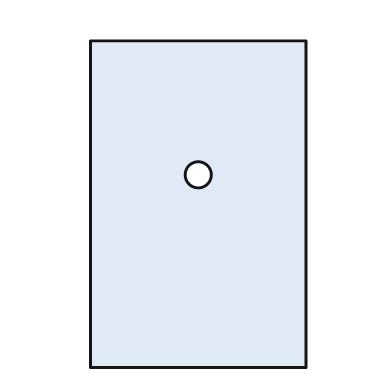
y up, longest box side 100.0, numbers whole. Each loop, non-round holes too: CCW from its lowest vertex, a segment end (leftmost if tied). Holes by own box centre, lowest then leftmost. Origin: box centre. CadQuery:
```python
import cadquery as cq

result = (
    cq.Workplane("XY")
    .moveTo(-33.0, -50.0)
    .lineTo(33.0, -50.0)
    .lineTo(33.0, 50.0)
    .lineTo(-33.0, 50.0)
    .close()
    .moveTo(0.0, 9.0)
    .circle(4.0)
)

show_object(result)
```